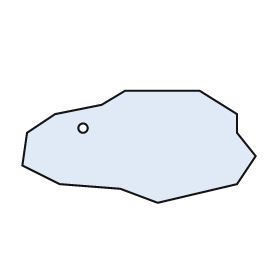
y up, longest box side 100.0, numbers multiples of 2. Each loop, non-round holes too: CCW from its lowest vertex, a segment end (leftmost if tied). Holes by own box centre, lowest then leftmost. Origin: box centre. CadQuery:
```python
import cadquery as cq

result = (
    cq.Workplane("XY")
    .moveTo(8.0, -24.0)
    .lineTo(42.0, -16.0)
    .lineTo(50.0, -4.0)
    .lineTo(42.0, 6.0)
    .lineTo(42.0, 14.0)
    .lineTo(26.0, 24.0)
    .lineTo(-6.0, 24.0)
    .lineTo(-16.0, 18.0)
    .lineTo(-36.0, 14.0)
    .lineTo(-48.0, 6.0)
    .lineTo(-50.0, -8.0)
    .lineTo(-34.0, -16.0)
    .lineTo(-8.0, -18.0)
    .close()
    .moveTo(-24.0, 8.0)
    .circle(2.0)
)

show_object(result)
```